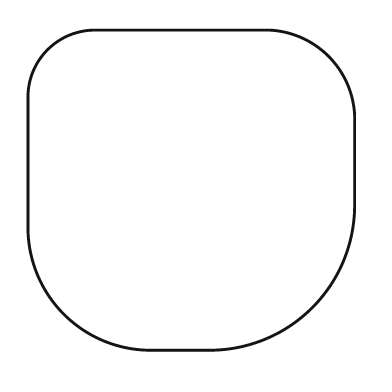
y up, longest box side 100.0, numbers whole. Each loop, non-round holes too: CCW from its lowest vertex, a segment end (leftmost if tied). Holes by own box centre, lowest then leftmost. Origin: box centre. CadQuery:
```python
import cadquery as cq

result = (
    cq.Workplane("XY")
    .moveTo(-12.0, -49.0)
    .lineTo(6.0, -49.0)
    .threePointArc((37.0, -36.0), (50.0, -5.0))
    .lineTo(50.0, 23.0)
    .threePointArc((42.0, 41.0), (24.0, 49.0))
    .lineTo(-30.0, 49.0)
    .threePointArc((-44.0, 43.0), (-50.0, 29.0))
    .lineTo(-50.0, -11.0)
    .threePointArc((-39.0, -38.0), (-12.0, -49.0))
    .close()
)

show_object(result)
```